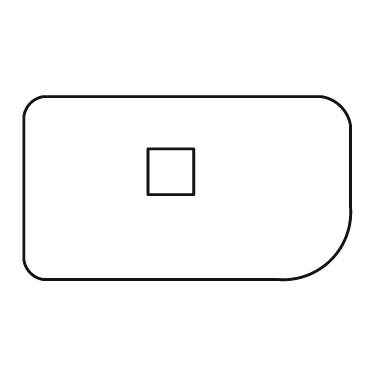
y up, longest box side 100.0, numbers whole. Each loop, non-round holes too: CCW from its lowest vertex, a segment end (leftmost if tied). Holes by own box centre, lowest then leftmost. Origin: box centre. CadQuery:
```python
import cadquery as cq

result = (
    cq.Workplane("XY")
    .moveTo(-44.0, -28.0)
    .lineTo(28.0, -28.0)
    .threePointArc((44.0, -22.0), (50.0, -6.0))
    .lineTo(50.0, 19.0)
    .threePointArc((47.0, 25.0), (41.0, 28.0))
    .lineTo(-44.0, 28.0)
    .threePointArc((-48.0, 26.0), (-50.0, 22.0))
    .lineTo(-50.0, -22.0)
    .threePointArc((-48.0, -26.0), (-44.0, -28.0))
    .close()
    .moveTo(-12.0, -2.0)
    .lineTo(2.0, -2.0)
    .lineTo(2.0, 12.0)
    .lineTo(-12.0, 12.0)
    .close()
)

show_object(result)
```